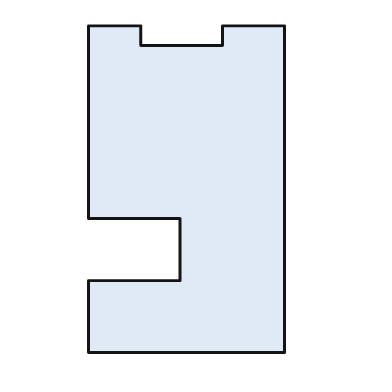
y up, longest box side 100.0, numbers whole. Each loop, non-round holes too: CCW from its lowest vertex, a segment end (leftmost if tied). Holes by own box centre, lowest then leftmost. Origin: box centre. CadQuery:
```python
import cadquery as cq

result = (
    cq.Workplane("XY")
    .moveTo(-30.0, -50.0)
    .lineTo(30.0, -50.0)
    .lineTo(30.0, 50.0)
    .lineTo(11.0, 50.0)
    .lineTo(11.0, 44.0)
    .lineTo(-14.0, 44.0)
    .lineTo(-14.0, 50.0)
    .lineTo(-30.0, 50.0)
    .lineTo(-30.0, -9.0)
    .lineTo(-2.0, -9.0)
    .lineTo(-2.0, -28.0)
    .lineTo(-30.0, -28.0)
    .close()
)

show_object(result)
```